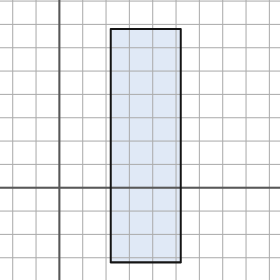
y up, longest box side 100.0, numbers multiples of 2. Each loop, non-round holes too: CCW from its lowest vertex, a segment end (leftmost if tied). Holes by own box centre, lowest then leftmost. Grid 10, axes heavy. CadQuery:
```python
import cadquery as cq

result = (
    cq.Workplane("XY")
    .moveTo(22.0, -32.0)
    .lineTo(52.0, -32.0)
    .lineTo(52.0, 68.0)
    .lineTo(22.0, 68.0)
    .close()
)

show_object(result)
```